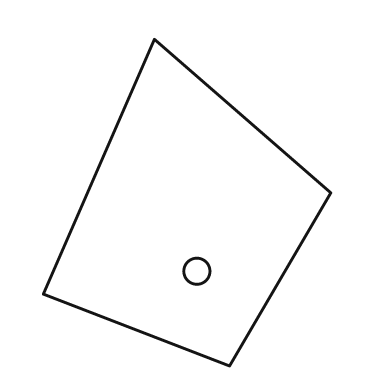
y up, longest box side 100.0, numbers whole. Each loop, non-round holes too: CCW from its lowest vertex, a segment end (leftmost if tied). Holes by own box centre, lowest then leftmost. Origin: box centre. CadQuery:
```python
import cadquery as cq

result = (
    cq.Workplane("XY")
    .moveTo(13.0, -50.0)
    .lineTo(44.0, 3.0)
    .lineTo(-10.0, 50.0)
    .lineTo(-44.0, -28.0)
    .close()
    .moveTo(3.0, -21.0)
    .circle(4.0)
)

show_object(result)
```